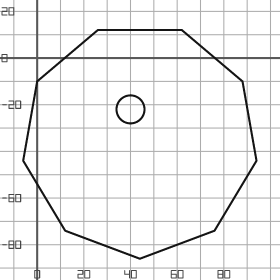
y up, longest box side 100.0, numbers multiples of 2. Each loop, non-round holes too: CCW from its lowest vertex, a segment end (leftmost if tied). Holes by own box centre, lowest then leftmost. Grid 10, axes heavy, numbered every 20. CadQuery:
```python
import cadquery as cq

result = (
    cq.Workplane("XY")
    .moveTo(44.0, -86.0)
    .lineTo(76.0, -74.0)
    .lineTo(94.0, -44.0)
    .lineTo(88.0, -10.0)
    .lineTo(62.0, 12.0)
    .lineTo(26.0, 12.0)
    .lineTo(0.0, -10.0)
    .lineTo(-6.0, -44.0)
    .lineTo(12.0, -74.0)
    .close()
    .moveTo(40.0, -22.0)
    .circle(6.0)
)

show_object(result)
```